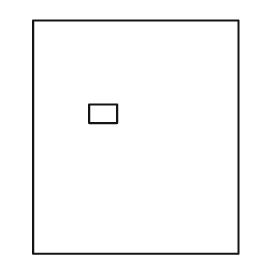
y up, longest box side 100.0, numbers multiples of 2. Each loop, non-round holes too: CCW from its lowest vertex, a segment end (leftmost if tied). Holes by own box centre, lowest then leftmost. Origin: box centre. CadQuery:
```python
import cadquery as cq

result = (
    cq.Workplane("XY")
    .moveTo(-44.0, -50.0)
    .lineTo(44.0, -50.0)
    .lineTo(44.0, 50.0)
    .lineTo(-44.0, 50.0)
    .close()
    .moveTo(-20.0, 6.0)
    .lineTo(-8.0, 6.0)
    .lineTo(-8.0, 14.0)
    .lineTo(-20.0, 14.0)
    .close()
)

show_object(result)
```